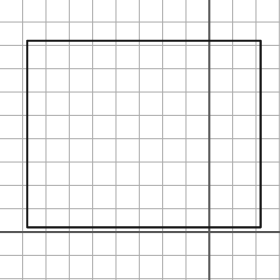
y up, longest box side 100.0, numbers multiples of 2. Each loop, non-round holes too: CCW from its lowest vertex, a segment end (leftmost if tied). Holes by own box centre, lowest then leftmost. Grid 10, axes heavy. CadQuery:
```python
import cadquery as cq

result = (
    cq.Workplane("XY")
    .moveTo(-78.0, 2.0)
    .lineTo(22.0, 2.0)
    .lineTo(22.0, 82.0)
    .lineTo(-78.0, 82.0)
    .close()
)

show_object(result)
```